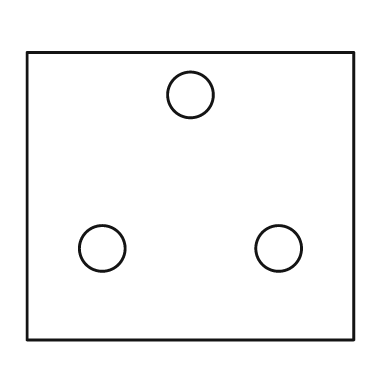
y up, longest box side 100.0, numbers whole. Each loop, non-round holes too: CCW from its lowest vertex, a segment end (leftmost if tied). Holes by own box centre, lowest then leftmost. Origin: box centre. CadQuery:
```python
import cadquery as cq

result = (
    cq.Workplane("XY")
    .moveTo(-50.0, -44.0)
    .lineTo(50.0, -44.0)
    .lineTo(50.0, 44.0)
    .lineTo(-50.0, 44.0)
    .close()
    .moveTo(-27.0, -16.0)
    .circle(7.0)
    .moveTo(27.0, -16.0)
    .circle(7.0)
    .moveTo(0.0, 31.0)
    .circle(7.0)
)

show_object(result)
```